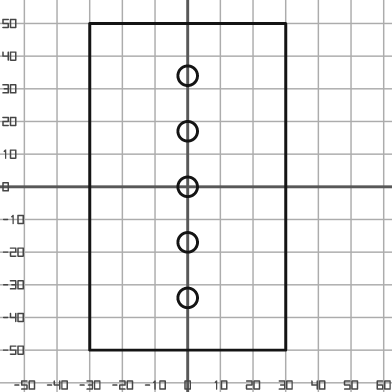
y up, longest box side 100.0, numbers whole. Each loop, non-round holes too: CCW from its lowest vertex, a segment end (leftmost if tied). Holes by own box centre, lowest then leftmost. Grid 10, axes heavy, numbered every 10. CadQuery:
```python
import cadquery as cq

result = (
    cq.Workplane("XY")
    .moveTo(-30.0, -50.0)
    .lineTo(30.0, -50.0)
    .lineTo(30.0, 50.0)
    .lineTo(-30.0, 50.0)
    .close()
    .moveTo(0.0, -34.0)
    .circle(3.0)
    .moveTo(0.0, -17.0)
    .circle(3.0)
    .moveTo(0.0, 0.0)
    .circle(3.0)
    .moveTo(0.0, 17.0)
    .circle(3.0)
    .moveTo(0.0, 34.0)
    .circle(3.0)
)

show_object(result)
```